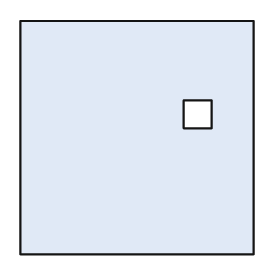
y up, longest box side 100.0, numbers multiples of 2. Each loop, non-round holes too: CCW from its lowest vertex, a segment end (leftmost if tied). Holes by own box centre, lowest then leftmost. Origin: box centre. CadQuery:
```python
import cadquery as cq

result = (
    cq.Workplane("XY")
    .moveTo(-50.0, -50.0)
    .lineTo(50.0, -50.0)
    .lineTo(50.0, 50.0)
    .lineTo(-50.0, 50.0)
    .close()
    .moveTo(20.0, 4.0)
    .lineTo(32.0, 4.0)
    .lineTo(32.0, 16.0)
    .lineTo(20.0, 16.0)
    .close()
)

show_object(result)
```